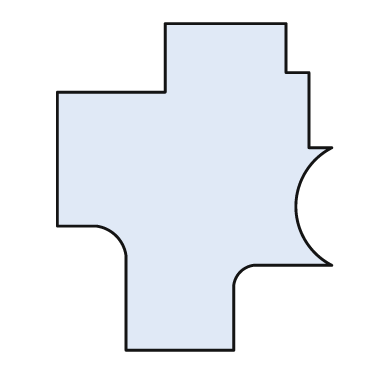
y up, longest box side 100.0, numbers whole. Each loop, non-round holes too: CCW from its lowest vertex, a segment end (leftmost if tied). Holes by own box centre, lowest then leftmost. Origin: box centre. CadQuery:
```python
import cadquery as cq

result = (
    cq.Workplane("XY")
    .moveTo(-21.0, -50.0)
    .lineTo(12.0, -50.0)
    .lineTo(12.0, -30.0)
    .threePointArc((14.0, -26.0), (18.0, -24.0))
    .lineTo(42.0, -24.0)
    .threePointArc((31.0, -6.0), (42.0, 12.0))
    .lineTo(35.0, 12.0)
    .lineTo(35.0, 35.0)
    .lineTo(28.0, 35.0)
    .lineTo(28.0, 50.0)
    .lineTo(-9.0, 50.0)
    .lineTo(-9.0, 29.0)
    .lineTo(-42.0, 29.0)
    .lineTo(-42.0, -12.0)
    .lineTo(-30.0, -12.0)
    .threePointArc((-24.0, -15.0), (-21.0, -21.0))
    .close()
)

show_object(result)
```